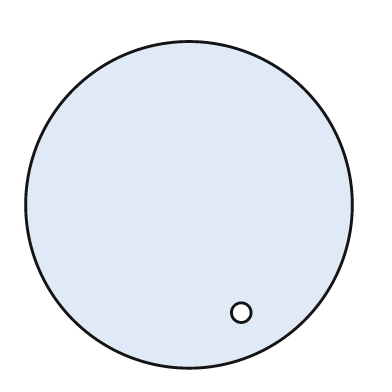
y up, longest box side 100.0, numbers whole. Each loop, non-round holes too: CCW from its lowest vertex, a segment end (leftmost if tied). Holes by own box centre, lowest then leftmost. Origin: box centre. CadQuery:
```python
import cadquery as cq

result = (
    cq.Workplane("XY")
    .moveTo(0.0, 0.0)
    .circle(50.0)
    .moveTo(16.0, -33.0)
    .circle(3.0)
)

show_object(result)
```